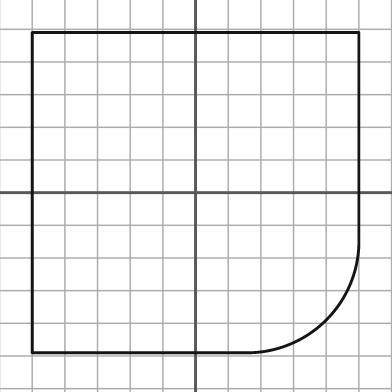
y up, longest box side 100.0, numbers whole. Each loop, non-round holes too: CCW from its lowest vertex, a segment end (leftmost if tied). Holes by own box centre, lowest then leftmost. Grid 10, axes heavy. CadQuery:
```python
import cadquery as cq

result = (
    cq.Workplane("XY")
    .moveTo(-50.0, -49.0)
    .lineTo(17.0, -49.0)
    .threePointArc((40.0, -39.0), (50.0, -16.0))
    .lineTo(50.0, 49.0)
    .lineTo(-50.0, 49.0)
    .close()
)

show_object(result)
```